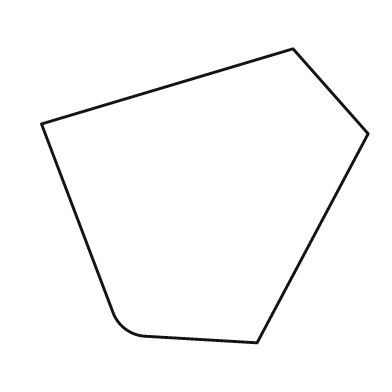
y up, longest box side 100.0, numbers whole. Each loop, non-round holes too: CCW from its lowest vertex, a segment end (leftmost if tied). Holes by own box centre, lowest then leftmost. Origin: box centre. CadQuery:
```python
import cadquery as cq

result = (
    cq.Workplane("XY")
    .moveTo(16.0, -45.0)
    .lineTo(50.0, 19.0)
    .lineTo(27.0, 45.0)
    .lineTo(-50.0, 22.0)
    .lineTo(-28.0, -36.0)
    .threePointArc((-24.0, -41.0), (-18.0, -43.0))
    .close()
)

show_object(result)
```